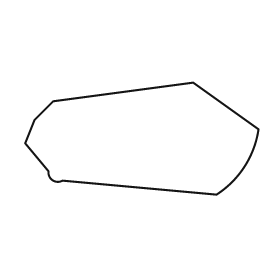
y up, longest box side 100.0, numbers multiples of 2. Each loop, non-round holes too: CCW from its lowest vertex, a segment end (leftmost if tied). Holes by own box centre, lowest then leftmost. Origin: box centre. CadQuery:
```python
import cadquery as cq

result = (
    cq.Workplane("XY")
    .moveTo(32.0, -24.0)
    .threePointArc((44.0, -12.0), (50.0, 4.0))
    .lineTo(22.0, 24.0)
    .lineTo(-38.0, 16.0)
    .lineTo(-46.0, 8.0)
    .lineTo(-50.0, -2.0)
    .lineTo(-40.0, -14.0)
    .threePointArc((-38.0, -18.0), (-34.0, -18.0))
    .close()
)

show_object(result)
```